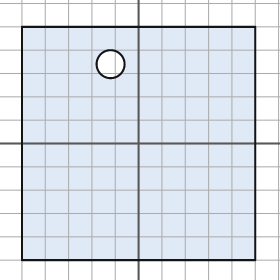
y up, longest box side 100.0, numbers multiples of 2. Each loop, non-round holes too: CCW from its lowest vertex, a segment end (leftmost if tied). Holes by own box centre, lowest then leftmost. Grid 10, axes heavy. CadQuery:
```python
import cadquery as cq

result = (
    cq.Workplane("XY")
    .moveTo(-50.0, -50.0)
    .lineTo(50.0, -50.0)
    .lineTo(50.0, 50.0)
    .lineTo(-50.0, 50.0)
    .close()
    .moveTo(-12.0, 34.0)
    .circle(6.0)
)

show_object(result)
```